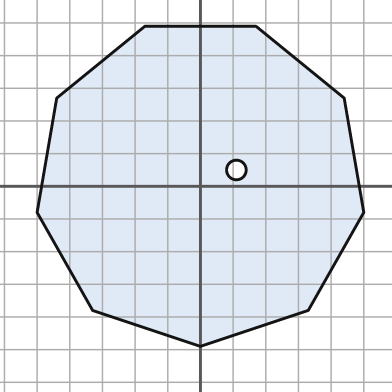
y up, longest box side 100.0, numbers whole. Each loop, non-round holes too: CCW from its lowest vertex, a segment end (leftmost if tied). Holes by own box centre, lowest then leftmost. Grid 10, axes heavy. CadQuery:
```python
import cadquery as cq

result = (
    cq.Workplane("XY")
    .moveTo(0.0, -49.0)
    .lineTo(33.0, -38.0)
    .lineTo(50.0, -8.0)
    .lineTo(44.0, 27.0)
    .lineTo(17.0, 49.0)
    .lineTo(-17.0, 49.0)
    .lineTo(-44.0, 27.0)
    .lineTo(-50.0, -8.0)
    .lineTo(-33.0, -38.0)
    .close()
    .moveTo(11.0, 5.0)
    .circle(3.0)
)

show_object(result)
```